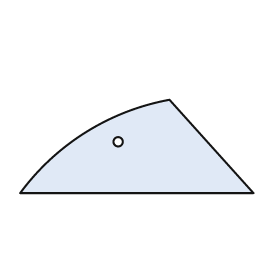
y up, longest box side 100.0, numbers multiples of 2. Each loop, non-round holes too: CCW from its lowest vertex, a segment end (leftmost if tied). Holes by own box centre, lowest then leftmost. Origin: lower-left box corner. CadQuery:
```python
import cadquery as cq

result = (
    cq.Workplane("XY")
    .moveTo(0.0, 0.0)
    .lineTo(100.0, 0.0)
    .lineTo(64.0, 40.0)
    .threePointArc((28.0, 26.0), (0.0, 0.0))
    .close()
    .moveTo(42.0, 22.0)
    .circle(2.0)
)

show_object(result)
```